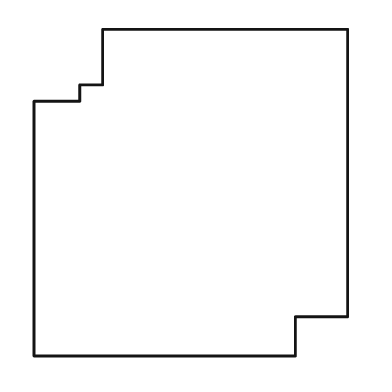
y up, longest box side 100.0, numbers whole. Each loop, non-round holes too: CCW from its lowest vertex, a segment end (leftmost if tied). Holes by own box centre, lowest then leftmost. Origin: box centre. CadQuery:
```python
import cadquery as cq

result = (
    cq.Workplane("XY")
    .moveTo(-48.0, -50.0)
    .lineTo(32.0, -50.0)
    .lineTo(32.0, -38.0)
    .lineTo(48.0, -38.0)
    .lineTo(48.0, 50.0)
    .lineTo(-27.0, 50.0)
    .lineTo(-27.0, 33.0)
    .lineTo(-34.0, 33.0)
    .lineTo(-34.0, 28.0)
    .lineTo(-48.0, 28.0)
    .close()
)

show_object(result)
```